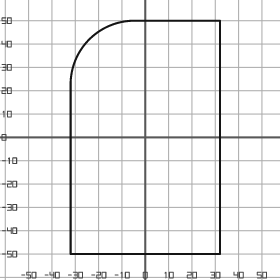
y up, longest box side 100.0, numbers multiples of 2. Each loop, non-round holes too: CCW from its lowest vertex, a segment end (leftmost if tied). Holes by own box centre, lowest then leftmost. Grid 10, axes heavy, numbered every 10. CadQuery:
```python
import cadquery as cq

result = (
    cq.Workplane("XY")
    .moveTo(-32.0, -50.0)
    .lineTo(32.0, -50.0)
    .lineTo(32.0, 50.0)
    .lineTo(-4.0, 50.0)
    .threePointArc((-24.0, 42.0), (-32.0, 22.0))
    .close()
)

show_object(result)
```